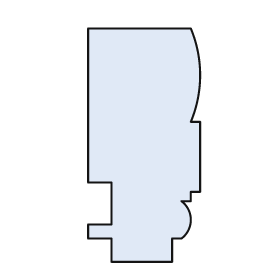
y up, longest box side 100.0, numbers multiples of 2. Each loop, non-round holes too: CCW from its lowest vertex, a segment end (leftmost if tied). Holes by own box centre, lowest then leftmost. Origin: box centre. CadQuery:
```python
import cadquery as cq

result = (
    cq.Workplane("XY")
    .moveTo(-14.0, -50.0)
    .lineTo(12.0, -50.0)
    .lineTo(12.0, -40.0)
    .lineTo(16.0, -40.0)
    .threePointArc((20.0, -32.0), (16.0, -24.0))
    .lineTo(20.0, -24.0)
    .lineTo(20.0, -20.0)
    .lineTo(24.0, -20.0)
    .lineTo(24.0, 10.0)
    .lineTo(20.0, 10.0)
    .threePointArc((24.0, 30.0), (20.0, 50.0))
    .lineTo(-24.0, 50.0)
    .lineTo(-24.0, -16.0)
    .lineTo(-14.0, -16.0)
    .lineTo(-14.0, -34.0)
    .lineTo(-24.0, -34.0)
    .lineTo(-24.0, -40.0)
    .lineTo(-14.0, -40.0)
    .close()
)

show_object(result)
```